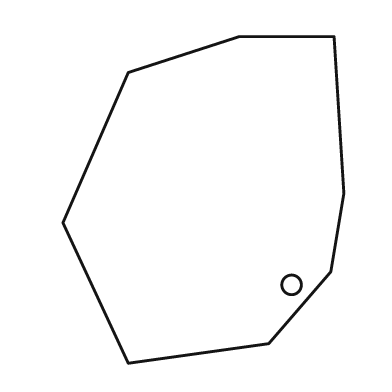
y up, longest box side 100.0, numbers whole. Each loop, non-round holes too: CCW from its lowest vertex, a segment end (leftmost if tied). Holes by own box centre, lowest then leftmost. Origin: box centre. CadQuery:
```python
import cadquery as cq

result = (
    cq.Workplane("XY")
    .moveTo(-23.0, -50.0)
    .lineTo(20.0, -44.0)
    .lineTo(39.0, -22.0)
    .lineTo(43.0, 2.0)
    .lineTo(40.0, 50.0)
    .lineTo(11.0, 50.0)
    .lineTo(-23.0, 39.0)
    .lineTo(-43.0, -7.0)
    .close()
    .moveTo(27.0, -26.0)
    .circle(3.0)
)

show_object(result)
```